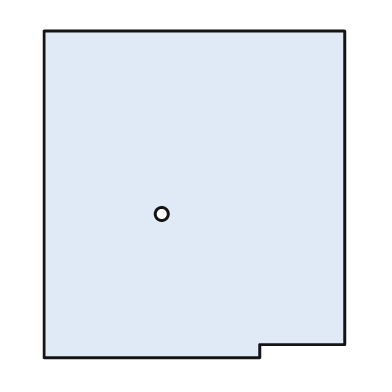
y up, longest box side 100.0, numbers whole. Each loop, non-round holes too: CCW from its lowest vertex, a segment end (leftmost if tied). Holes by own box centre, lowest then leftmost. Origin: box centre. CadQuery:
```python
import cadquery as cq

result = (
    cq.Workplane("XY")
    .moveTo(-46.0, -50.0)
    .lineTo(20.0, -50.0)
    .lineTo(20.0, -46.0)
    .lineTo(46.0, -46.0)
    .lineTo(46.0, 50.0)
    .lineTo(-46.0, 50.0)
    .close()
    .moveTo(-10.0, -6.0)
    .circle(2.0)
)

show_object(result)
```